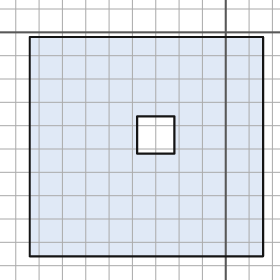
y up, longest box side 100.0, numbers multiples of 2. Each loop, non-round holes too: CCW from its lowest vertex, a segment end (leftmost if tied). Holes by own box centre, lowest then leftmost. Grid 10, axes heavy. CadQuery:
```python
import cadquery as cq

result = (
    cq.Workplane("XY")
    .moveTo(-84.0, -96.0)
    .lineTo(16.0, -96.0)
    .lineTo(16.0, -2.0)
    .lineTo(-84.0, -2.0)
    .close()
    .moveTo(-38.0, -52.0)
    .lineTo(-22.0, -52.0)
    .lineTo(-22.0, -36.0)
    .lineTo(-38.0, -36.0)
    .close()
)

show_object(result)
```